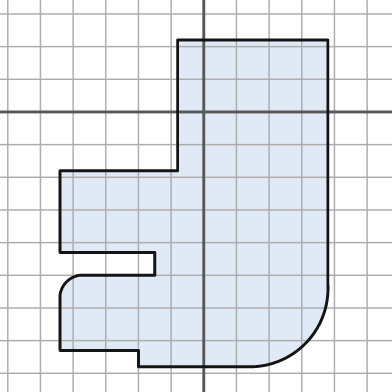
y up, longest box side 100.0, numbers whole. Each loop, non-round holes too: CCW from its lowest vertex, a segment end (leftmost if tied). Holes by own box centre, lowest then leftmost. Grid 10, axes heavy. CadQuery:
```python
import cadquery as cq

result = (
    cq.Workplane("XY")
    .moveTo(-20.0, -78.0)
    .lineTo(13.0, -78.0)
    .threePointArc((31.0, -71.0), (38.0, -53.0))
    .lineTo(38.0, 22.0)
    .lineTo(-8.0, 22.0)
    .lineTo(-8.0, -18.0)
    .lineTo(-44.0, -18.0)
    .lineTo(-44.0, -43.0)
    .lineTo(-15.0, -43.0)
    .lineTo(-15.0, -50.0)
    .lineTo(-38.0, -50.0)
    .threePointArc((-42.0, -52.0), (-44.0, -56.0))
    .lineTo(-44.0, -73.0)
    .lineTo(-20.0, -73.0)
    .close()
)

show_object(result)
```